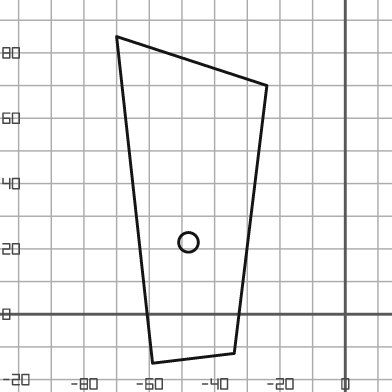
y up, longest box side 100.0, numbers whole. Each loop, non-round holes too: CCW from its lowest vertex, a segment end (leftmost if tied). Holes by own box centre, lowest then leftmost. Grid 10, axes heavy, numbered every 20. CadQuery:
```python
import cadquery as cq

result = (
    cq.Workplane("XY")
    .moveTo(-59.0, -15.0)
    .lineTo(-34.0, -12.0)
    .lineTo(-24.0, 70.0)
    .lineTo(-70.0, 85.0)
    .close()
    .moveTo(-48.0, 22.0)
    .circle(3.0)
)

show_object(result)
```